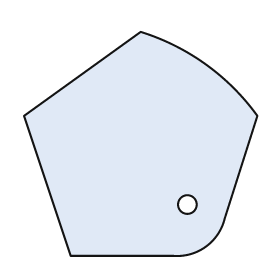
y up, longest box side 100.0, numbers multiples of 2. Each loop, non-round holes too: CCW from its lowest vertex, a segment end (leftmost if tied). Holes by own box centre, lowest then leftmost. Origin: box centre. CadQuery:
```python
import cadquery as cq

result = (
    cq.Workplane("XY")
    .moveTo(-30.0, -48.0)
    .lineTo(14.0, -48.0)
    .threePointArc((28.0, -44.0), (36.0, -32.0))
    .lineTo(50.0, 12.0)
    .threePointArc((28.0, 34.0), (0.0, 48.0))
    .lineTo(-50.0, 12.0)
    .close()
    .moveTo(20.0, -26.0)
    .circle(4.0)
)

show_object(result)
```